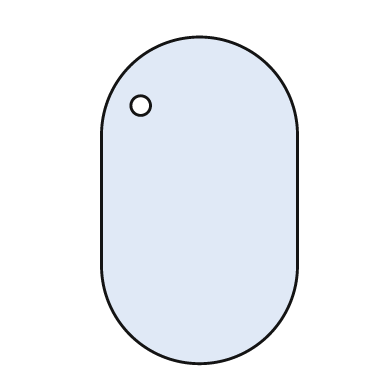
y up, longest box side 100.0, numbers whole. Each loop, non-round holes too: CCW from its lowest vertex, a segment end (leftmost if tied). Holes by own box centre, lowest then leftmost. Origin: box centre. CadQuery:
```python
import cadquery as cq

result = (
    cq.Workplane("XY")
    .moveTo(-30.0, -20.0)
    .threePointArc((0.0, -50.0), (30.0, -20.0))
    .lineTo(30.0, 20.0)
    .threePointArc((0.0, 50.0), (-30.0, 20.0))
    .close()
    .moveTo(-18.0, 29.0)
    .circle(3.0)
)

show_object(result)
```